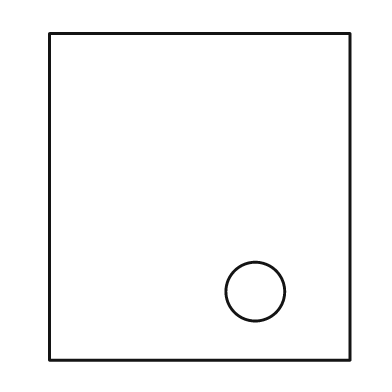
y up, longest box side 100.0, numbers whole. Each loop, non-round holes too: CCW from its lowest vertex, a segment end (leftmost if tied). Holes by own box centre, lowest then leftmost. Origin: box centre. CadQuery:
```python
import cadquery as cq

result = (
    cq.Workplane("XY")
    .moveTo(-46.0, -50.0)
    .lineTo(46.0, -50.0)
    .lineTo(46.0, 50.0)
    .lineTo(-46.0, 50.0)
    .close()
    .moveTo(17.0, -29.0)
    .circle(9.0)
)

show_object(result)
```